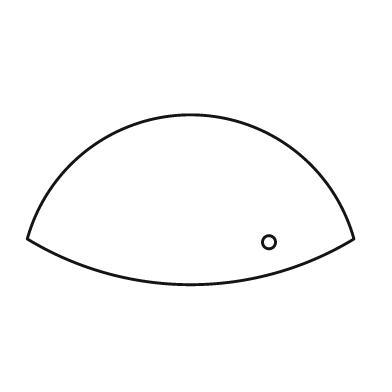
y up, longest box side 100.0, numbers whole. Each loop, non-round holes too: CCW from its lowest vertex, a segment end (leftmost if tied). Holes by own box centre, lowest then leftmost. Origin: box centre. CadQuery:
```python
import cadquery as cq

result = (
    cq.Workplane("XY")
    .moveTo(-50.0, -12.0)
    .threePointArc((0.0, -26.0), (50.0, -12.0))
    .threePointArc((0.0, 26.0), (-50.0, -12.0))
    .close()
    .moveTo(24.0, -13.0)
    .circle(2.0)
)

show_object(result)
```